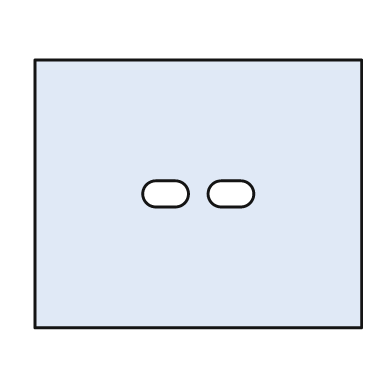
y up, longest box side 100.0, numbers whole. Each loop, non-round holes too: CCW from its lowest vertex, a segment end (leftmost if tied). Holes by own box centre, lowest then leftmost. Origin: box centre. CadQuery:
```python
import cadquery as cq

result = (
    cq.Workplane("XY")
    .moveTo(-50.0, -41.0)
    .lineTo(50.0, -41.0)
    .lineTo(50.0, 41.0)
    .lineTo(-50.0, 41.0)
    .close()
    .moveTo(-13.0, -4.0)
    .lineTo(-7.0, -4.0)
    .threePointArc((-3.0, 0.0), (-7.0, 4.0))
    .lineTo(-13.0, 4.0)
    .threePointArc((-17.0, 0.0), (-13.0, -4.0))
    .close()
    .moveTo(7.0, -4.0)
    .lineTo(13.0, -4.0)
    .threePointArc((17.0, 0.0), (13.0, 4.0))
    .lineTo(7.0, 4.0)
    .threePointArc((3.0, 0.0), (7.0, -4.0))
    .close()
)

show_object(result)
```